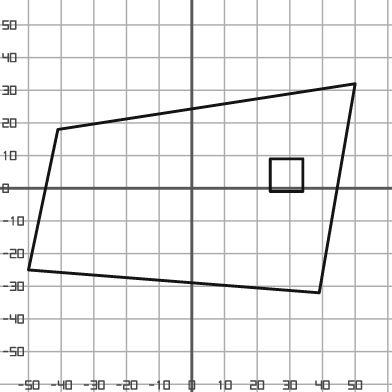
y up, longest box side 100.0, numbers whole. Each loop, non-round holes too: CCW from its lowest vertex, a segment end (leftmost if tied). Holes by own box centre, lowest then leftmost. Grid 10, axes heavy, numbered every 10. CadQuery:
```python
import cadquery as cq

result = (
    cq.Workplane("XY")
    .moveTo(39.0, -32.0)
    .lineTo(50.0, 32.0)
    .lineTo(-41.0, 18.0)
    .lineTo(-50.0, -25.0)
    .close()
    .moveTo(24.0, -1.0)
    .lineTo(34.0, -1.0)
    .lineTo(34.0, 9.0)
    .lineTo(24.0, 9.0)
    .close()
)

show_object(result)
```